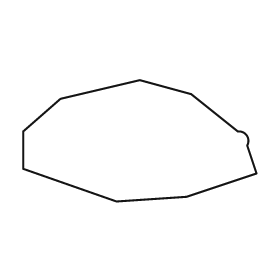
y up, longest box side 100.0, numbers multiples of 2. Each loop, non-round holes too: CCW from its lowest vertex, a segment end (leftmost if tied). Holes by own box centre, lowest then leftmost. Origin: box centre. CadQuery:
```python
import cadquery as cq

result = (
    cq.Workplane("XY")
    .moveTo(-10.0, -26.0)
    .lineTo(20.0, -24.0)
    .lineTo(50.0, -14.0)
    .lineTo(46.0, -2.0)
    .threePointArc((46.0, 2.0), (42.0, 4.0))
    .lineTo(22.0, 20.0)
    .lineTo(0.0, 26.0)
    .lineTo(-34.0, 18.0)
    .lineTo(-50.0, 4.0)
    .lineTo(-50.0, -12.0)
    .close()
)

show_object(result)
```